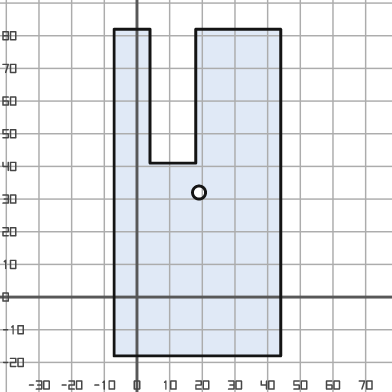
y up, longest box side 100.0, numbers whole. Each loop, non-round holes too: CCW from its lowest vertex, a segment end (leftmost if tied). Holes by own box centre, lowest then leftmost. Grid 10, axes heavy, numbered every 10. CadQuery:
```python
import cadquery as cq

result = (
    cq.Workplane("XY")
    .moveTo(-7.0, -18.0)
    .lineTo(44.0, -18.0)
    .lineTo(44.0, 82.0)
    .lineTo(18.0, 82.0)
    .lineTo(18.0, 41.0)
    .lineTo(4.0, 41.0)
    .lineTo(4.0, 82.0)
    .lineTo(-7.0, 82.0)
    .close()
    .moveTo(19.0, 32.0)
    .circle(2.0)
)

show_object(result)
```